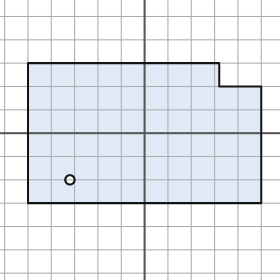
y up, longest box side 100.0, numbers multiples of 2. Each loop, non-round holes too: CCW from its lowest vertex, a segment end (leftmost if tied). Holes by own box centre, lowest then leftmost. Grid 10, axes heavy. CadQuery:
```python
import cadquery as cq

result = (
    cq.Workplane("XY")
    .moveTo(-50.0, -30.0)
    .lineTo(50.0, -30.0)
    .lineTo(50.0, 20.0)
    .lineTo(32.0, 20.0)
    .lineTo(32.0, 30.0)
    .lineTo(-50.0, 30.0)
    .close()
    .moveTo(-32.0, -20.0)
    .circle(2.0)
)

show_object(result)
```